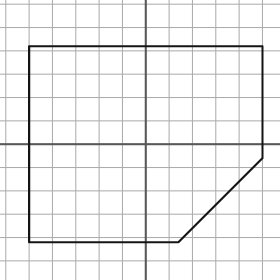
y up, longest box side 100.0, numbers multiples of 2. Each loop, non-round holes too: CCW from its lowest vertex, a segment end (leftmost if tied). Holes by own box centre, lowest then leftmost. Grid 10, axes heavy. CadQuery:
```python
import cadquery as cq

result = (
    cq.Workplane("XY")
    .moveTo(-50.0, -42.0)
    .lineTo(14.0, -42.0)
    .lineTo(50.0, -6.0)
    .lineTo(50.0, 42.0)
    .lineTo(-50.0, 42.0)
    .close()
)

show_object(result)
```